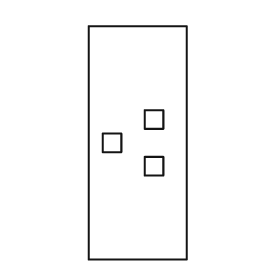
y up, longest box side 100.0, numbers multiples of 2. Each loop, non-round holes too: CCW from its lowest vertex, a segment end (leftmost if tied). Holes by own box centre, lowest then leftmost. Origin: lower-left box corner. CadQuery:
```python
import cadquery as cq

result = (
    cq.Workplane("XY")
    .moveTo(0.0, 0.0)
    .lineTo(42.0, 0.0)
    .lineTo(42.0, 100.0)
    .lineTo(0.0, 100.0)
    .close()
    .moveTo(24.0, 36.0)
    .lineTo(32.0, 36.0)
    .lineTo(32.0, 44.0)
    .lineTo(24.0, 44.0)
    .close()
    .moveTo(6.0, 46.0)
    .lineTo(14.0, 46.0)
    .lineTo(14.0, 54.0)
    .lineTo(6.0, 54.0)
    .close()
    .moveTo(24.0, 56.0)
    .lineTo(32.0, 56.0)
    .lineTo(32.0, 64.0)
    .lineTo(24.0, 64.0)
    .close()
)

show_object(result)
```